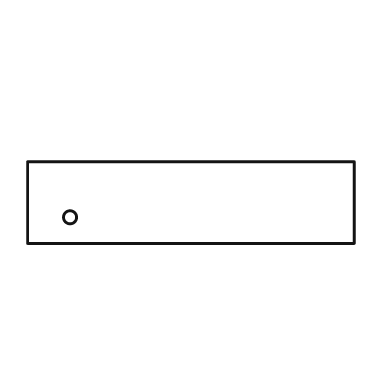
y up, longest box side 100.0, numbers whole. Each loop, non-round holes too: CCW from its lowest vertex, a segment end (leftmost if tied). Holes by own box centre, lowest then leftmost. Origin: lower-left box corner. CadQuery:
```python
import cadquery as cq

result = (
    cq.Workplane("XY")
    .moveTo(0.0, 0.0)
    .lineTo(100.0, 0.0)
    .lineTo(100.0, 25.0)
    .lineTo(0.0, 25.0)
    .close()
    .moveTo(13.0, 8.0)
    .circle(2.0)
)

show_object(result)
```